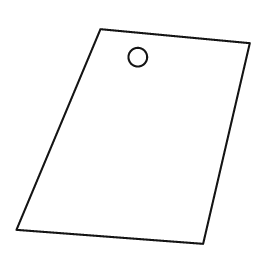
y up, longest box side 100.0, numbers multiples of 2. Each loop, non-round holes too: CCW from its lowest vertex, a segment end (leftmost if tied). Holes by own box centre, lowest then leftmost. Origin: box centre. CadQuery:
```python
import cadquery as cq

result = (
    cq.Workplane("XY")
    .moveTo(30.0, -46.0)
    .lineTo(50.0, 40.0)
    .lineTo(-14.0, 46.0)
    .lineTo(-50.0, -40.0)
    .close()
    .moveTo(2.0, 34.0)
    .circle(4.0)
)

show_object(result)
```